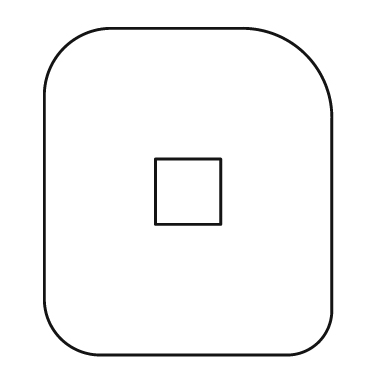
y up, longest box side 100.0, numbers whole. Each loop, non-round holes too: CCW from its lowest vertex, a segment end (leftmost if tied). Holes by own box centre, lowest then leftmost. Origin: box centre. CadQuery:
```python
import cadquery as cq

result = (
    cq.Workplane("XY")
    .moveTo(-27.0, -50.0)
    .lineTo(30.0, -50.0)
    .threePointArc((40.0, -46.0), (44.0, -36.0))
    .lineTo(44.0, 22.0)
    .threePointArc((36.0, 42.0), (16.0, 50.0))
    .lineTo(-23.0, 50.0)
    .threePointArc((-38.0, 44.0), (-44.0, 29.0))
    .lineTo(-44.0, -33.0)
    .threePointArc((-39.0, -45.0), (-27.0, -50.0))
    .close()
    .moveTo(-10.0, -10.0)
    .lineTo(10.0, -10.0)
    .lineTo(10.0, 10.0)
    .lineTo(-10.0, 10.0)
    .close()
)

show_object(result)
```